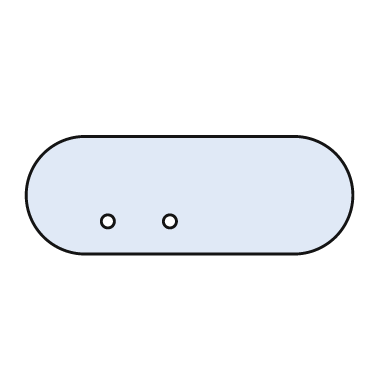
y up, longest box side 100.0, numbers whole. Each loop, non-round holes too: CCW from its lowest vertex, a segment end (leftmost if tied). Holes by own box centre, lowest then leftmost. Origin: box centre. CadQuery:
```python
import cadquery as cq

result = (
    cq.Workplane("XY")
    .moveTo(-32.0, -18.0)
    .lineTo(32.0, -18.0)
    .threePointArc((50.0, 0.0), (32.0, 18.0))
    .lineTo(-32.0, 18.0)
    .threePointArc((-50.0, 0.0), (-32.0, -18.0))
    .close()
    .moveTo(-25.0, -8.0)
    .circle(2.0)
    .moveTo(-6.0, -8.0)
    .circle(2.0)
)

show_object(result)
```